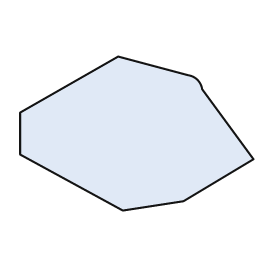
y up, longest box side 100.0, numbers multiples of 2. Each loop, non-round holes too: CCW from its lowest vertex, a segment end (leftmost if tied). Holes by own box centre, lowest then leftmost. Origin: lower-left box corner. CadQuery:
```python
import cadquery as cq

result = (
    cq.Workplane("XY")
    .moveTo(44.0, 0.0)
    .lineTo(70.0, 4.0)
    .lineTo(100.0, 22.0)
    .lineTo(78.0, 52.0)
    .threePointArc((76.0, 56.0), (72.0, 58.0))
    .lineTo(42.0, 66.0)
    .lineTo(0.0, 42.0)
    .lineTo(0.0, 24.0)
    .close()
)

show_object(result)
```